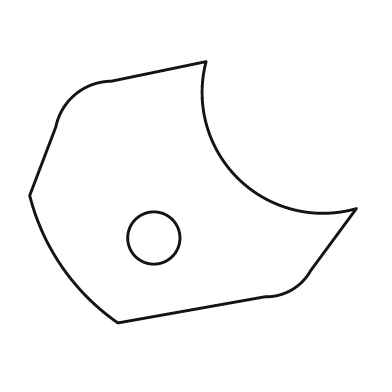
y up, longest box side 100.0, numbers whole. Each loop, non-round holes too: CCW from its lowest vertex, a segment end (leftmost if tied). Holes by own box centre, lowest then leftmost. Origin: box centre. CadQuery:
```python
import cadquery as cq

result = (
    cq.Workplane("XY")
    .moveTo(-23.0, -40.0)
    .lineTo(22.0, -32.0)
    .threePointArc((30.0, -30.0), (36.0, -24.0))
    .lineTo(50.0, -5.0)
    .threePointArc((14.0, 4.0), (4.0, 40.0))
    .lineTo(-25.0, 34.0)
    .threePointArc((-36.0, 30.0), (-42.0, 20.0))
    .lineTo(-50.0, -1.0)
    .threePointArc((-40.0, -23.0), (-23.0, -40.0))
    .close()
    .moveTo(-12.0, -14.0)
    .circle(8.0)
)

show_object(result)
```